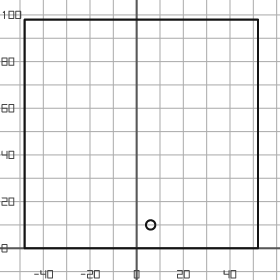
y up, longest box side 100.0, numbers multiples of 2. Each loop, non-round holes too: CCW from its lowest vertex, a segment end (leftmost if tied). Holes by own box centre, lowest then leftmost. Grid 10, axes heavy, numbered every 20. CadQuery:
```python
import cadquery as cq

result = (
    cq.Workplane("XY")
    .moveTo(-48.0, 0.0)
    .lineTo(52.0, 0.0)
    .lineTo(52.0, 98.0)
    .lineTo(-48.0, 98.0)
    .close()
    .moveTo(6.0, 10.0)
    .circle(2.0)
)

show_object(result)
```